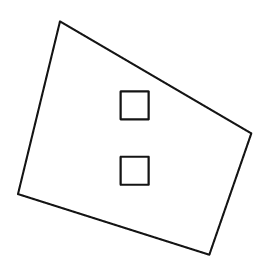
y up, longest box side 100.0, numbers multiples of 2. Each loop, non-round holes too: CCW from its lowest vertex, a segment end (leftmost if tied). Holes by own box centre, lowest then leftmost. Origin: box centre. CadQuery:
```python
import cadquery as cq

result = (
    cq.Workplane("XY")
    .moveTo(32.0, -50.0)
    .lineTo(50.0, 2.0)
    .lineTo(-32.0, 50.0)
    .lineTo(-50.0, -24.0)
    .close()
    .moveTo(-6.0, -20.0)
    .lineTo(6.0, -20.0)
    .lineTo(6.0, -8.0)
    .lineTo(-6.0, -8.0)
    .close()
    .moveTo(-6.0, 8.0)
    .lineTo(6.0, 8.0)
    .lineTo(6.0, 20.0)
    .lineTo(-6.0, 20.0)
    .close()
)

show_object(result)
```